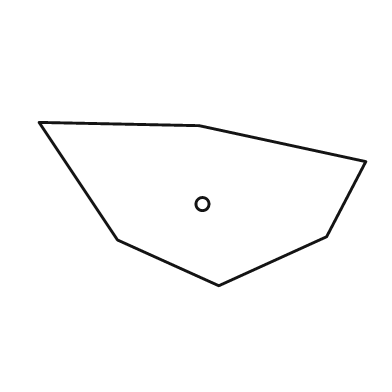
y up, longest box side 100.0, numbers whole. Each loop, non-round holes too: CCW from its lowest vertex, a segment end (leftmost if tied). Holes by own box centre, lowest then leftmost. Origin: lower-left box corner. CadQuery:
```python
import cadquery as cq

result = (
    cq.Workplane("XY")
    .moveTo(55.0, 0.0)
    .lineTo(88.0, 15.0)
    .lineTo(100.0, 38.0)
    .lineTo(49.0, 49.0)
    .lineTo(0.0, 50.0)
    .lineTo(24.0, 14.0)
    .close()
    .moveTo(50.0, 25.0)
    .circle(2.0)
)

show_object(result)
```